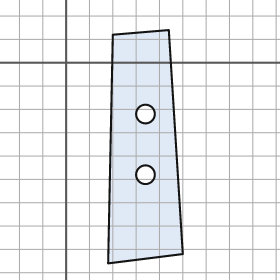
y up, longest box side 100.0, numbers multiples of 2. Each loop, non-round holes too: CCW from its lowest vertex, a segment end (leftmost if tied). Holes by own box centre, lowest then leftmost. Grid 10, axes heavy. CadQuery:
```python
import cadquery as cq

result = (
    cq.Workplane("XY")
    .moveTo(18.0, -86.0)
    .lineTo(50.0, -82.0)
    .lineTo(44.0, 14.0)
    .lineTo(20.0, 12.0)
    .close()
    .moveTo(34.0, -48.0)
    .circle(4.0)
    .moveTo(34.0, -22.0)
    .circle(4.0)
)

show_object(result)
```